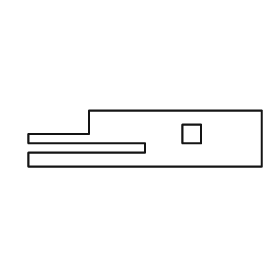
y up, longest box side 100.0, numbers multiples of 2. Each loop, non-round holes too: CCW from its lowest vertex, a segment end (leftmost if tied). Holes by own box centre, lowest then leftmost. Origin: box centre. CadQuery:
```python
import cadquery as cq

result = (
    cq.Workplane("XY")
    .moveTo(-50.0, -12.0)
    .lineTo(50.0, -12.0)
    .lineTo(50.0, 12.0)
    .lineTo(-24.0, 12.0)
    .lineTo(-24.0, 2.0)
    .lineTo(-50.0, 2.0)
    .lineTo(-50.0, -2.0)
    .lineTo(0.0, -2.0)
    .lineTo(0.0, -6.0)
    .lineTo(-50.0, -6.0)
    .close()
    .moveTo(16.0, -2.0)
    .lineTo(24.0, -2.0)
    .lineTo(24.0, 6.0)
    .lineTo(16.0, 6.0)
    .close()
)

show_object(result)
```